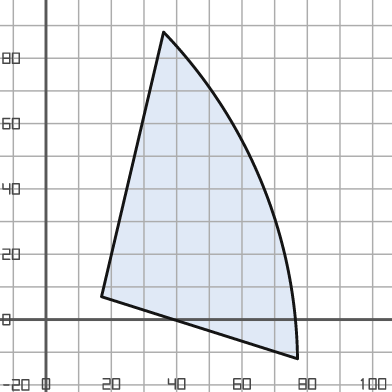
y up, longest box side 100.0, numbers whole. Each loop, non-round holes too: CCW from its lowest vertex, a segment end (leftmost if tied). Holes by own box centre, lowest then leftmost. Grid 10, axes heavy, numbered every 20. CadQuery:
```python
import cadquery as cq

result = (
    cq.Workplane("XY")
    .moveTo(77.0, -12.0)
    .threePointArc((66.0, 42.0), (36.0, 88.0))
    .lineTo(17.0, 7.0)
    .close()
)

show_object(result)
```